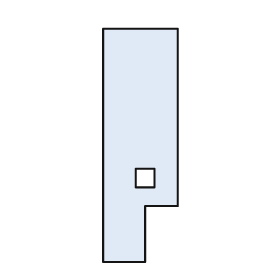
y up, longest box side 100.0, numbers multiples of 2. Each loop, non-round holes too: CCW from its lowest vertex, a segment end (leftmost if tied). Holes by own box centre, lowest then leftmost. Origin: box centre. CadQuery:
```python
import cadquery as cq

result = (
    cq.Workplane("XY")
    .moveTo(-16.0, -50.0)
    .lineTo(2.0, -50.0)
    .lineTo(2.0, -26.0)
    .lineTo(16.0, -26.0)
    .lineTo(16.0, 50.0)
    .lineTo(-16.0, 50.0)
    .close()
    .moveTo(-2.0, -18.0)
    .lineTo(6.0, -18.0)
    .lineTo(6.0, -10.0)
    .lineTo(-2.0, -10.0)
    .close()
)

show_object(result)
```